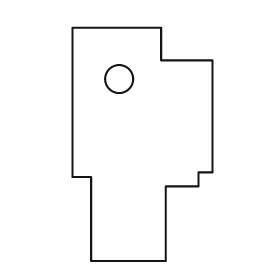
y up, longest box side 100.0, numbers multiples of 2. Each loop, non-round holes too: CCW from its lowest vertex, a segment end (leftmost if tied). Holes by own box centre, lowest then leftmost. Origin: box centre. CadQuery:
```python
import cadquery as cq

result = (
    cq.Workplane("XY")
    .moveTo(-22.0, -50.0)
    .lineTo(10.0, -50.0)
    .lineTo(10.0, -18.0)
    .lineTo(24.0, -18.0)
    .lineTo(24.0, -12.0)
    .lineTo(30.0, -12.0)
    .lineTo(30.0, 36.0)
    .lineTo(8.0, 36.0)
    .lineTo(8.0, 50.0)
    .lineTo(-30.0, 50.0)
    .lineTo(-30.0, -14.0)
    .lineTo(-22.0, -14.0)
    .close()
    .moveTo(-10.0, 28.0)
    .circle(6.0)
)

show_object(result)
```